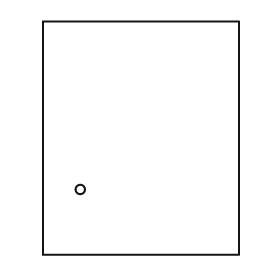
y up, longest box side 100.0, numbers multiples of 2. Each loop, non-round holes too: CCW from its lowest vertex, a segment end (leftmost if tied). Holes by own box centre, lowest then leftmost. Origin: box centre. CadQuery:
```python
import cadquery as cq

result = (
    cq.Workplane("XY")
    .moveTo(-42.0, -50.0)
    .lineTo(42.0, -50.0)
    .lineTo(42.0, 50.0)
    .lineTo(-42.0, 50.0)
    .close()
    .moveTo(-26.0, -22.0)
    .circle(2.0)
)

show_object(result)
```